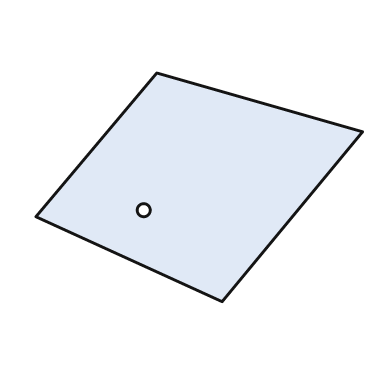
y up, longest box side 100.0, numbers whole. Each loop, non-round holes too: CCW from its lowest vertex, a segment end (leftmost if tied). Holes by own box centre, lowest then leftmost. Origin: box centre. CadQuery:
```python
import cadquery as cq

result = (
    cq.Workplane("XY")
    .moveTo(7.0, -35.0)
    .lineTo(50.0, 17.0)
    .lineTo(-13.0, 35.0)
    .lineTo(-50.0, -9.0)
    .close()
    .moveTo(-17.0, -7.0)
    .circle(2.0)
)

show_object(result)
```